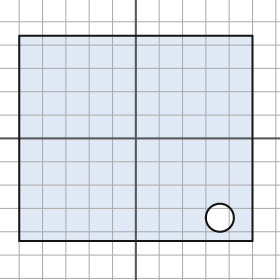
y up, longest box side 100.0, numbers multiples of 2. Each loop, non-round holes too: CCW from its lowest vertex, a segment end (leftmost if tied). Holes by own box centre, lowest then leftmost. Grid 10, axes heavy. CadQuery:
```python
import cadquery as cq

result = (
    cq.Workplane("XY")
    .moveTo(-50.0, -44.0)
    .lineTo(50.0, -44.0)
    .lineTo(50.0, 44.0)
    .lineTo(-50.0, 44.0)
    .close()
    .moveTo(36.0, -34.0)
    .circle(6.0)
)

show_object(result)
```